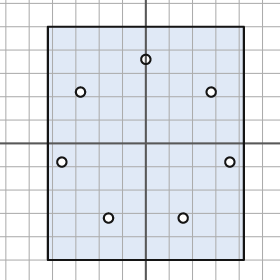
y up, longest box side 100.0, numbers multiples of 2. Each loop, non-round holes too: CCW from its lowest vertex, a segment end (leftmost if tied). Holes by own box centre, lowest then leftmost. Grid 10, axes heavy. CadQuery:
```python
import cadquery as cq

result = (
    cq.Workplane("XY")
    .moveTo(-42.0, -50.0)
    .lineTo(42.0, -50.0)
    .lineTo(42.0, 50.0)
    .lineTo(-42.0, 50.0)
    .close()
    .moveTo(-16.0, -32.0)
    .circle(2.0)
    .moveTo(16.0, -32.0)
    .circle(2.0)
    .moveTo(-36.0, -8.0)
    .circle(2.0)
    .moveTo(36.0, -8.0)
    .circle(2.0)
    .moveTo(-28.0, 22.0)
    .circle(2.0)
    .moveTo(28.0, 22.0)
    .circle(2.0)
    .moveTo(0.0, 36.0)
    .circle(2.0)
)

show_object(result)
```